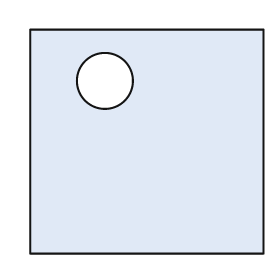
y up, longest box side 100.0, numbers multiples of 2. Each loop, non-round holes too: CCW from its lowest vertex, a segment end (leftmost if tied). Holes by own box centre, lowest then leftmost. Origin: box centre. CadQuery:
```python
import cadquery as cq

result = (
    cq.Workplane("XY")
    .moveTo(-50.0, -48.0)
    .lineTo(50.0, -48.0)
    .lineTo(50.0, 48.0)
    .lineTo(-50.0, 48.0)
    .close()
    .moveTo(-18.0, 26.0)
    .circle(12.0)
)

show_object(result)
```